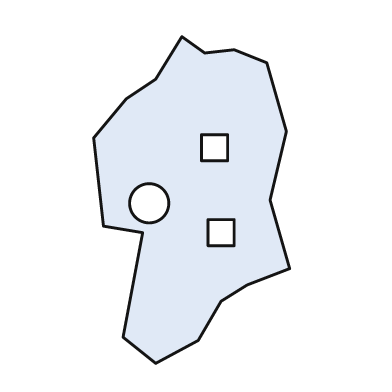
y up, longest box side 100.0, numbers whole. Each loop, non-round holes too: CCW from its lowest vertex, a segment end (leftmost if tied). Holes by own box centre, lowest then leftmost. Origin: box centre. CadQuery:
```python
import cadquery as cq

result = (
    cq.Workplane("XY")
    .moveTo(-11.0, -50.0)
    .lineTo(2.0, -43.0)
    .lineTo(9.0, -31.0)
    .lineTo(17.0, -26.0)
    .lineTo(30.0, -21.0)
    .lineTo(24.0, 0.0)
    .lineTo(29.0, 21.0)
    .lineTo(23.0, 42.0)
    .lineTo(13.0, 46.0)
    .lineTo(4.0, 45.0)
    .lineTo(-3.0, 50.0)
    .lineTo(-11.0, 37.0)
    .lineTo(-20.0, 31.0)
    .lineTo(-30.0, 19.0)
    .lineTo(-27.0, -8.0)
    .lineTo(-15.0, -10.0)
    .lineTo(-21.0, -42.0)
    .close()
    .moveTo(5.0, -14.0)
    .lineTo(13.0, -14.0)
    .lineTo(13.0, -6.0)
    .lineTo(5.0, -6.0)
    .close()
    .moveTo(-13.0, -1.0)
    .circle(6.0)
    .moveTo(3.0, 12.0)
    .lineTo(11.0, 12.0)
    .lineTo(11.0, 20.0)
    .lineTo(3.0, 20.0)
    .close()
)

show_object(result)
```